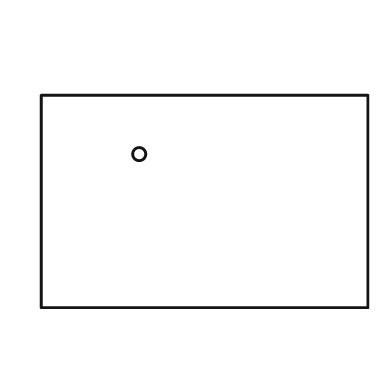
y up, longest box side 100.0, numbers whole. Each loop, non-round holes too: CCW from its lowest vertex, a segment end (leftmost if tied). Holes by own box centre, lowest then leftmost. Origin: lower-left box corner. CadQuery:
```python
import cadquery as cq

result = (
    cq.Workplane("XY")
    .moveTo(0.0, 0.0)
    .lineTo(100.0, 0.0)
    .lineTo(100.0, 65.0)
    .lineTo(0.0, 65.0)
    .close()
    .moveTo(30.0, 47.0)
    .circle(2.0)
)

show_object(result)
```